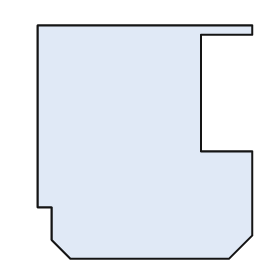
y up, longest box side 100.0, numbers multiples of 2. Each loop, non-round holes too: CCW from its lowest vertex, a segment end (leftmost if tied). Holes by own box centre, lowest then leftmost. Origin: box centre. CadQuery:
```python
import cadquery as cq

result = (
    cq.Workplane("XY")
    .moveTo(-32.0, -50.0)
    .lineTo(36.0, -50.0)
    .lineTo(46.0, -40.0)
    .lineTo(46.0, -4.0)
    .lineTo(24.0, -4.0)
    .lineTo(24.0, 46.0)
    .lineTo(46.0, 46.0)
    .lineTo(46.0, 50.0)
    .lineTo(-46.0, 50.0)
    .lineTo(-46.0, -28.0)
    .lineTo(-40.0, -28.0)
    .lineTo(-40.0, -42.0)
    .close()
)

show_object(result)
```